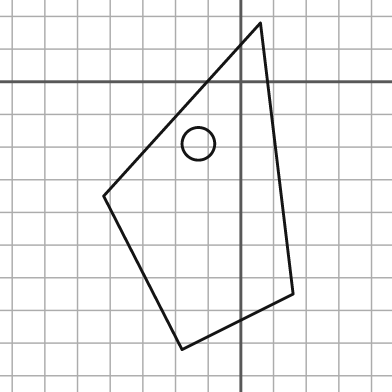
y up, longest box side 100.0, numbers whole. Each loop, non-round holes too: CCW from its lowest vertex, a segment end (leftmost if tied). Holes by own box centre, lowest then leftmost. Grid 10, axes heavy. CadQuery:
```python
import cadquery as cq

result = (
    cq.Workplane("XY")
    .moveTo(-18.0, -82.0)
    .lineTo(16.0, -65.0)
    .lineTo(6.0, 18.0)
    .lineTo(-42.0, -35.0)
    .close()
    .moveTo(-13.0, -19.0)
    .circle(5.0)
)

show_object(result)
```